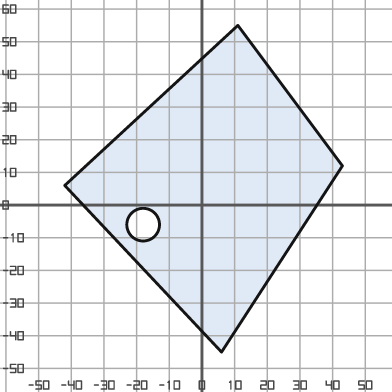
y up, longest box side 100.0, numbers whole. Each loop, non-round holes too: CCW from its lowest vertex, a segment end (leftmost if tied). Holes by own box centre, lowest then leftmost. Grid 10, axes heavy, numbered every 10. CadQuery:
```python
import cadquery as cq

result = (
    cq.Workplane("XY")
    .moveTo(6.0, -45.0)
    .lineTo(43.0, 12.0)
    .lineTo(11.0, 55.0)
    .lineTo(-42.0, 6.0)
    .close()
    .moveTo(-18.0, -6.0)
    .circle(5.0)
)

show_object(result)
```